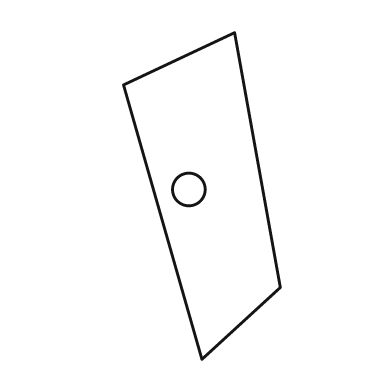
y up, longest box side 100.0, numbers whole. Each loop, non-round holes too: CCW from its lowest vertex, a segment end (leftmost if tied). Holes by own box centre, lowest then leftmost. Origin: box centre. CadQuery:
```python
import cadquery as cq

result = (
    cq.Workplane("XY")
    .moveTo(0.0, -50.0)
    .lineTo(24.0, -28.0)
    .lineTo(10.0, 50.0)
    .lineTo(-24.0, 34.0)
    .close()
    .moveTo(-4.0, 2.0)
    .circle(5.0)
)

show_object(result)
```